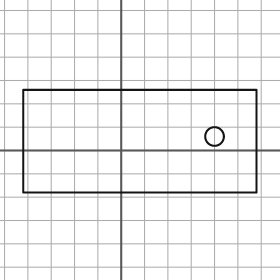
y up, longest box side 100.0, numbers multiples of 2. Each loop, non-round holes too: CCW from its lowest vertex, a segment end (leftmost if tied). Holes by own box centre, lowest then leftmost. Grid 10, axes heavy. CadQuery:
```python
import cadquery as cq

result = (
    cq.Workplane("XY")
    .moveTo(-42.0, -18.0)
    .lineTo(58.0, -18.0)
    .lineTo(58.0, 26.0)
    .lineTo(-42.0, 26.0)
    .close()
    .moveTo(40.0, 6.0)
    .circle(4.0)
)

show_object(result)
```